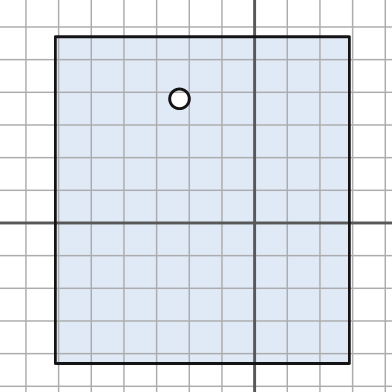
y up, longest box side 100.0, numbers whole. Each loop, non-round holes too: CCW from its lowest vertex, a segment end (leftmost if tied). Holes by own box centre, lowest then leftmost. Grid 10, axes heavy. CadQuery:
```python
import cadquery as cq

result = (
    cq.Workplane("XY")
    .moveTo(-61.0, -43.0)
    .lineTo(29.0, -43.0)
    .lineTo(29.0, 57.0)
    .lineTo(-61.0, 57.0)
    .close()
    .moveTo(-23.0, 38.0)
    .circle(3.0)
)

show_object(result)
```